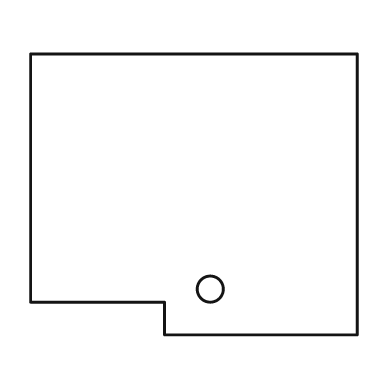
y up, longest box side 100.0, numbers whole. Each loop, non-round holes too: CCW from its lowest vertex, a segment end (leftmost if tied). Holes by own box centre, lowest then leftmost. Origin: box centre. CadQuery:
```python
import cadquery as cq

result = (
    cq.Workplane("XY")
    .moveTo(-9.0, -43.0)
    .lineTo(50.0, -43.0)
    .lineTo(50.0, 43.0)
    .lineTo(-50.0, 43.0)
    .lineTo(-50.0, -33.0)
    .lineTo(-9.0, -33.0)
    .close()
    .moveTo(5.0, -29.0)
    .circle(4.0)
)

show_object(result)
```